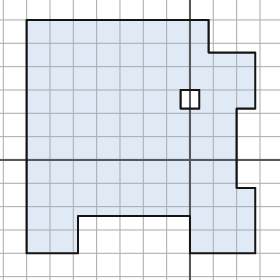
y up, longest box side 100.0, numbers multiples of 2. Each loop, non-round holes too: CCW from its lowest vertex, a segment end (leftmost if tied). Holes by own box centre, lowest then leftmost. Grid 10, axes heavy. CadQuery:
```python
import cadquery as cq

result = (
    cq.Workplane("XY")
    .moveTo(-70.0, -40.0)
    .lineTo(-48.0, -40.0)
    .lineTo(-48.0, -24.0)
    .lineTo(0.0, -24.0)
    .lineTo(0.0, -40.0)
    .lineTo(28.0, -40.0)
    .lineTo(28.0, -12.0)
    .lineTo(20.0, -12.0)
    .lineTo(20.0, 22.0)
    .lineTo(28.0, 22.0)
    .lineTo(28.0, 46.0)
    .lineTo(8.0, 46.0)
    .lineTo(8.0, 60.0)
    .lineTo(-70.0, 60.0)
    .close()
    .moveTo(-4.0, 22.0)
    .lineTo(4.0, 22.0)
    .lineTo(4.0, 30.0)
    .lineTo(-4.0, 30.0)
    .close()
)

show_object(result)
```